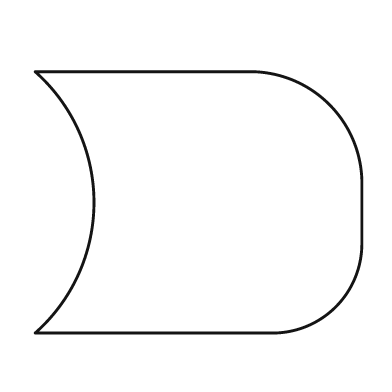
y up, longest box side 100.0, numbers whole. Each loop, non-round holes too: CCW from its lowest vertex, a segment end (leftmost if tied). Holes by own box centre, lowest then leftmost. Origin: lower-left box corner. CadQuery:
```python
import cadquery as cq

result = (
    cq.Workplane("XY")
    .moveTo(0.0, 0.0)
    .lineTo(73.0, 0.0)
    .threePointArc((92.0, 8.0), (100.0, 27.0))
    .lineTo(100.0, 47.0)
    .threePointArc((90.0, 70.0), (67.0, 80.0))
    .lineTo(0.0, 80.0)
    .threePointArc((18.0, 40.0), (0.0, 0.0))
    .close()
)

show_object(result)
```